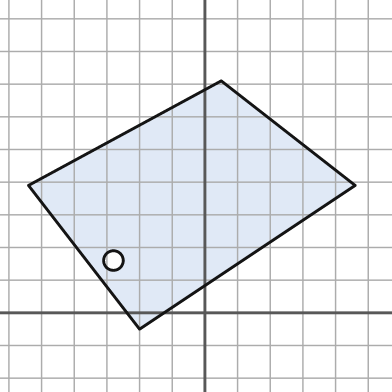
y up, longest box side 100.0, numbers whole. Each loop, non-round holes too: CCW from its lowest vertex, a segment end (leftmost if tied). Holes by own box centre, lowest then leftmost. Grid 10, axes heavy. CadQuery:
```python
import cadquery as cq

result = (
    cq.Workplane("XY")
    .moveTo(-20.0, -5.0)
    .lineTo(46.0, 39.0)
    .lineTo(5.0, 71.0)
    .lineTo(-54.0, 39.0)
    .close()
    .moveTo(-28.0, 16.0)
    .circle(3.0)
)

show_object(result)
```